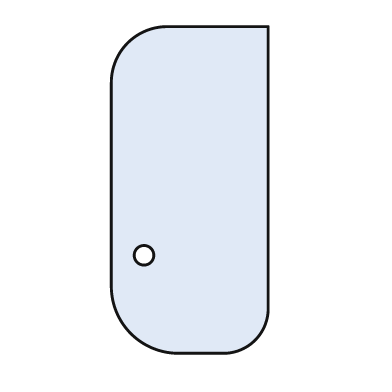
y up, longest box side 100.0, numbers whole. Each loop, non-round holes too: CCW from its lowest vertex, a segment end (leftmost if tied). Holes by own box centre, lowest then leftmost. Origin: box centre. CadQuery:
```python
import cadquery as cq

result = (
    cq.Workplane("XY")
    .moveTo(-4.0, -50.0)
    .lineTo(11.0, -50.0)
    .threePointArc((20.0, -46.0), (24.0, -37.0))
    .lineTo(24.0, 50.0)
    .lineTo(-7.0, 50.0)
    .threePointArc((-19.0, 45.0), (-24.0, 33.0))
    .lineTo(-24.0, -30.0)
    .threePointArc((-18.0, -44.0), (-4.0, -50.0))
    .close()
    .moveTo(-14.0, -20.0)
    .circle(3.0)
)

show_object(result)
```